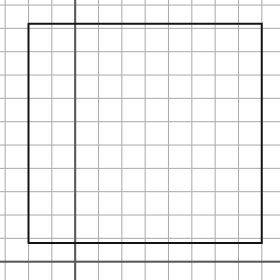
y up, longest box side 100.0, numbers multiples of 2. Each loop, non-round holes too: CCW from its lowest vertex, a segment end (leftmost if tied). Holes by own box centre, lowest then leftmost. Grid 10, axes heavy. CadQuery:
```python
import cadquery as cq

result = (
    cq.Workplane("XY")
    .moveTo(-20.0, 8.0)
    .lineTo(80.0, 8.0)
    .lineTo(80.0, 102.0)
    .lineTo(-20.0, 102.0)
    .close()
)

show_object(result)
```